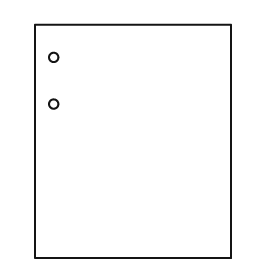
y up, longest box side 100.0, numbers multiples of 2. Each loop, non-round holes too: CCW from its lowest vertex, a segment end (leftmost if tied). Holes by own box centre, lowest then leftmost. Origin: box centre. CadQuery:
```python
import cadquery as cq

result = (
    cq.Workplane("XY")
    .moveTo(-42.0, -50.0)
    .lineTo(42.0, -50.0)
    .lineTo(42.0, 50.0)
    .lineTo(-42.0, 50.0)
    .close()
    .moveTo(-34.0, 16.0)
    .circle(2.0)
    .moveTo(-34.0, 36.0)
    .circle(2.0)
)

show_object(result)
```